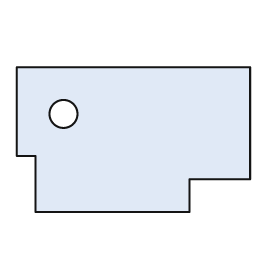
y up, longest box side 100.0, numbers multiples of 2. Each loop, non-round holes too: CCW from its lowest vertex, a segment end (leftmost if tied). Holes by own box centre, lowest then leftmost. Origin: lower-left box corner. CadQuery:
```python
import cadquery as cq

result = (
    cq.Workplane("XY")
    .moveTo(8.0, 0.0)
    .lineTo(74.0, 0.0)
    .lineTo(74.0, 14.0)
    .lineTo(100.0, 14.0)
    .lineTo(100.0, 62.0)
    .lineTo(0.0, 62.0)
    .lineTo(0.0, 24.0)
    .lineTo(8.0, 24.0)
    .close()
    .moveTo(20.0, 42.0)
    .circle(6.0)
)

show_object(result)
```